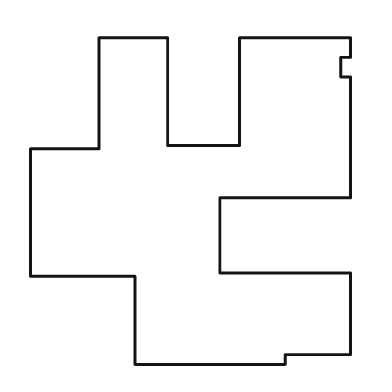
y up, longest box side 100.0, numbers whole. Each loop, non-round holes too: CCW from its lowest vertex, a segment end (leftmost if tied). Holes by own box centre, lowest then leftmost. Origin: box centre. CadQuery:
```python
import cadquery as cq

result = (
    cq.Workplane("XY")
    .moveTo(-17.0, -50.0)
    .lineTo(29.0, -50.0)
    .lineTo(29.0, -47.0)
    .lineTo(49.0, -47.0)
    .lineTo(49.0, -22.0)
    .lineTo(9.0, -22.0)
    .lineTo(9.0, 1.0)
    .lineTo(49.0, 1.0)
    .lineTo(49.0, 38.0)
    .lineTo(46.0, 38.0)
    .lineTo(46.0, 44.0)
    .lineTo(49.0, 44.0)
    .lineTo(49.0, 50.0)
    .lineTo(15.0, 50.0)
    .lineTo(15.0, 17.0)
    .lineTo(-7.0, 17.0)
    .lineTo(-7.0, 50.0)
    .lineTo(-28.0, 50.0)
    .lineTo(-28.0, 16.0)
    .lineTo(-49.0, 16.0)
    .lineTo(-49.0, -23.0)
    .lineTo(-17.0, -23.0)
    .close()
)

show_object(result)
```